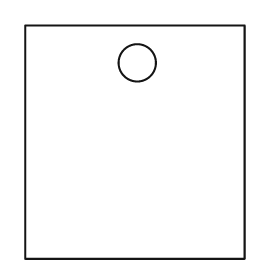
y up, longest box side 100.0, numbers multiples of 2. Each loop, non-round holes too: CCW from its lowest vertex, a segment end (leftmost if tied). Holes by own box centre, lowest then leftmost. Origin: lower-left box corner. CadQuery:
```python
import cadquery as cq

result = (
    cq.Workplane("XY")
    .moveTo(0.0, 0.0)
    .lineTo(94.0, 0.0)
    .lineTo(94.0, 100.0)
    .lineTo(0.0, 100.0)
    .close()
    .moveTo(48.0, 84.0)
    .circle(8.0)
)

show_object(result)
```